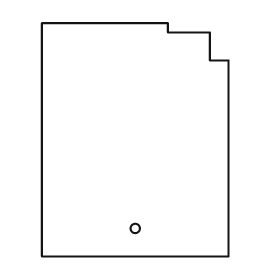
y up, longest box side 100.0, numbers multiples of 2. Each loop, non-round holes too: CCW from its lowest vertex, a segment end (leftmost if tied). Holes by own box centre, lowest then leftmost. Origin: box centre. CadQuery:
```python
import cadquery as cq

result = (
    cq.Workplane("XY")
    .moveTo(-40.0, -50.0)
    .lineTo(40.0, -50.0)
    .lineTo(40.0, 34.0)
    .lineTo(32.0, 34.0)
    .lineTo(32.0, 46.0)
    .lineTo(14.0, 46.0)
    .lineTo(14.0, 50.0)
    .lineTo(-40.0, 50.0)
    .close()
    .moveTo(0.0, -38.0)
    .circle(2.0)
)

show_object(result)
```